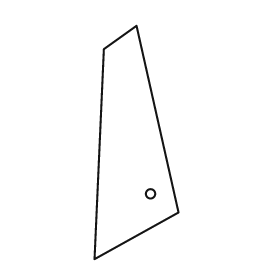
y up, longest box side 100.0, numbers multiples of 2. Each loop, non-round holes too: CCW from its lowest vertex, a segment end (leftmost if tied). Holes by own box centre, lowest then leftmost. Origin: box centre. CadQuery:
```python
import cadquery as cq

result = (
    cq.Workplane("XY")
    .moveTo(-18.0, -50.0)
    .lineTo(18.0, -30.0)
    .lineTo(0.0, 50.0)
    .lineTo(-14.0, 40.0)
    .close()
    .moveTo(6.0, -22.0)
    .circle(2.0)
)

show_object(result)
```